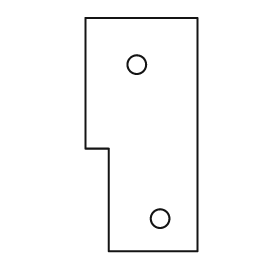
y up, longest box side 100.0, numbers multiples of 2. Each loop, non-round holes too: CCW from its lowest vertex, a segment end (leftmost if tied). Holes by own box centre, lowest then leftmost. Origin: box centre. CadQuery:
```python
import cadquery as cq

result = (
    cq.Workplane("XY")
    .moveTo(-14.0, -50.0)
    .lineTo(24.0, -50.0)
    .lineTo(24.0, 50.0)
    .lineTo(-24.0, 50.0)
    .lineTo(-24.0, -6.0)
    .lineTo(-14.0, -6.0)
    .close()
    .moveTo(8.0, -36.0)
    .circle(4.0)
    .moveTo(-2.0, 30.0)
    .circle(4.0)
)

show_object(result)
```